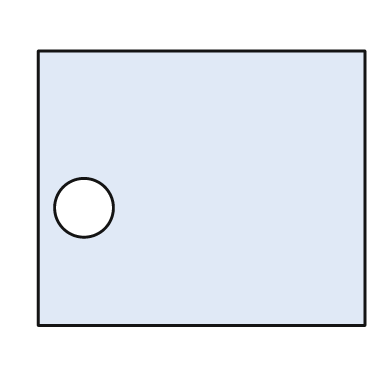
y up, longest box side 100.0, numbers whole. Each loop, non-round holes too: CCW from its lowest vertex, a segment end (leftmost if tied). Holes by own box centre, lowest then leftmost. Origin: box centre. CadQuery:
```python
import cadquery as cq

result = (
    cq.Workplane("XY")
    .moveTo(-50.0, -42.0)
    .lineTo(50.0, -42.0)
    .lineTo(50.0, 42.0)
    .lineTo(-50.0, 42.0)
    .close()
    .moveTo(-36.0, -6.0)
    .circle(9.0)
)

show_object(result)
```